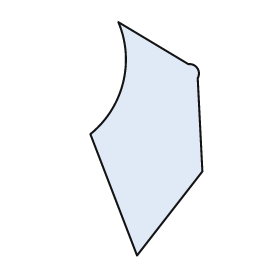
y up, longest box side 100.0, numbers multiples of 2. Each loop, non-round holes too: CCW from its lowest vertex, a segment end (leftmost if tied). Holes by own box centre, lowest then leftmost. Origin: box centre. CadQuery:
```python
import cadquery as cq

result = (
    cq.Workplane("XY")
    .moveTo(-4.0, -50.0)
    .lineTo(24.0, -14.0)
    .lineTo(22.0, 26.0)
    .threePointArc((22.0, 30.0), (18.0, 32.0))
    .lineTo(-12.0, 50.0)
    .threePointArc((-10.0, 24.0), (-24.0, 2.0))
    .close()
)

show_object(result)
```